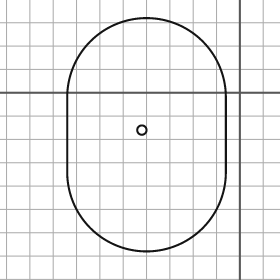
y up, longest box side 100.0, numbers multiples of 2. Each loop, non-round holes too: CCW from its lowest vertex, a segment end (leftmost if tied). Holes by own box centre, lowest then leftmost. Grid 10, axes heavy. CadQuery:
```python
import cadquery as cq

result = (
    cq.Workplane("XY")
    .moveTo(-74.0, -34.0)
    .threePointArc((-40.0, -68.0), (-6.0, -34.0))
    .lineTo(-6.0, -2.0)
    .threePointArc((-40.0, 32.0), (-74.0, -2.0))
    .close()
    .moveTo(-42.0, -16.0)
    .circle(2.0)
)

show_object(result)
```